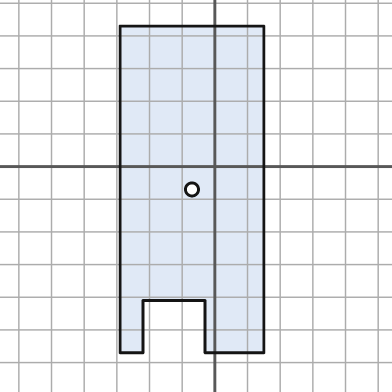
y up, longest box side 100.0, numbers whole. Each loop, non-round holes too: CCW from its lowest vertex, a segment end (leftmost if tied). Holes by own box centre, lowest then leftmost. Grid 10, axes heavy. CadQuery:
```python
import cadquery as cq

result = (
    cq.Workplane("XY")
    .moveTo(-29.0, -57.0)
    .lineTo(-22.0, -57.0)
    .lineTo(-22.0, -41.0)
    .lineTo(-3.0, -41.0)
    .lineTo(-3.0, -57.0)
    .lineTo(15.0, -57.0)
    .lineTo(15.0, 43.0)
    .lineTo(-29.0, 43.0)
    .close()
    .moveTo(-7.0, -7.0)
    .circle(2.0)
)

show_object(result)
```